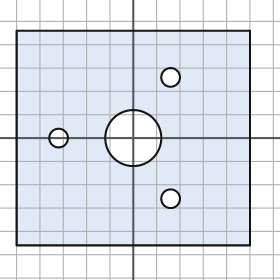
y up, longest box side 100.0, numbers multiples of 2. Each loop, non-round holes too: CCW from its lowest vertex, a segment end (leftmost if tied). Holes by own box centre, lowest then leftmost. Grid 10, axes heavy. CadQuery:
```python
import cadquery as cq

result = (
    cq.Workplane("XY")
    .moveTo(-50.0, -46.0)
    .lineTo(50.0, -46.0)
    .lineTo(50.0, 46.0)
    .lineTo(-50.0, 46.0)
    .close()
    .moveTo(16.0, -26.0)
    .circle(4.0)
    .moveTo(-32.0, 0.0)
    .circle(4.0)
    .moveTo(0.0, 0.0)
    .circle(12.0)
    .moveTo(16.0, 26.0)
    .circle(4.0)
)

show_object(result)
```